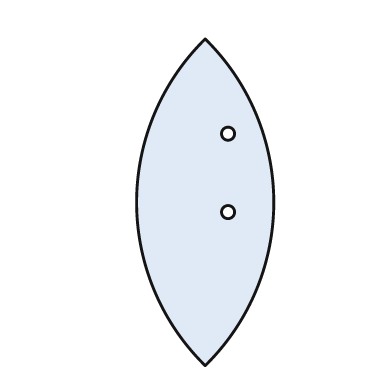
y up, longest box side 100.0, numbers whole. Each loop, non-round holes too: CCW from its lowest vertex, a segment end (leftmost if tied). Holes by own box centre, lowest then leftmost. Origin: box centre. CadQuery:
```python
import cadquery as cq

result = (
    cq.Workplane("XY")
    .moveTo(0.0, -50.0)
    .threePointArc((21.0, 0.0), (0.0, 50.0))
    .threePointArc((-21.0, 0.0), (0.0, -50.0))
    .close()
    .moveTo(7.0, -3.0)
    .circle(2.0)
    .moveTo(7.0, 21.0)
    .circle(2.0)
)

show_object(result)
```